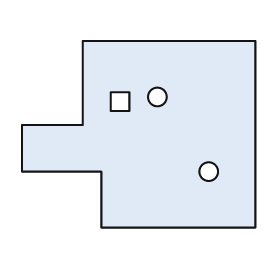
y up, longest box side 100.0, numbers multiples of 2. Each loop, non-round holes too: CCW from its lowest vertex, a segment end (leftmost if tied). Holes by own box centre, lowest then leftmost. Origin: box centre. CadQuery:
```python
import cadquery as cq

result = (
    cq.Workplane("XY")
    .moveTo(-16.0, -40.0)
    .lineTo(50.0, -40.0)
    .lineTo(50.0, 40.0)
    .lineTo(-24.0, 40.0)
    .lineTo(-24.0, 4.0)
    .lineTo(-50.0, 4.0)
    .lineTo(-50.0, -16.0)
    .lineTo(-16.0, -16.0)
    .close()
    .moveTo(30.0, -16.0)
    .circle(4.0)
    .moveTo(-12.0, 10.0)
    .lineTo(-4.0, 10.0)
    .lineTo(-4.0, 18.0)
    .lineTo(-12.0, 18.0)
    .close()
    .moveTo(8.0, 16.0)
    .circle(4.0)
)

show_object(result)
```